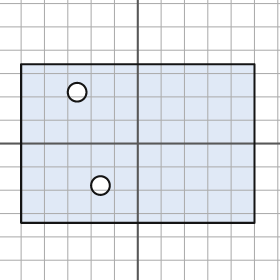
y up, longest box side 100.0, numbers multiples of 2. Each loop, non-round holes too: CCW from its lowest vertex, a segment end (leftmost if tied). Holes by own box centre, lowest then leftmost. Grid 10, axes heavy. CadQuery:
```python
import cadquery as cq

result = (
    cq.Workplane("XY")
    .moveTo(-50.0, -34.0)
    .lineTo(50.0, -34.0)
    .lineTo(50.0, 34.0)
    .lineTo(-50.0, 34.0)
    .close()
    .moveTo(-16.0, -18.0)
    .circle(4.0)
    .moveTo(-26.0, 22.0)
    .circle(4.0)
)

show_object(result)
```